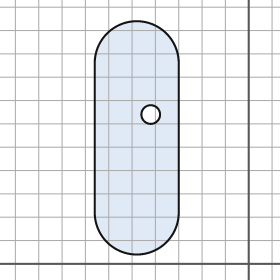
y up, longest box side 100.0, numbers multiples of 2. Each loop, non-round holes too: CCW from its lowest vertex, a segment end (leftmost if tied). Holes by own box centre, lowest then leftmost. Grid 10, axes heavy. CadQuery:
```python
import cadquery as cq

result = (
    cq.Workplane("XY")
    .moveTo(-66.0, 22.0)
    .threePointArc((-48.0, 4.0), (-30.0, 22.0))
    .lineTo(-30.0, 86.0)
    .threePointArc((-48.0, 104.0), (-66.0, 86.0))
    .close()
    .moveTo(-42.0, 64.0)
    .circle(4.0)
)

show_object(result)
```